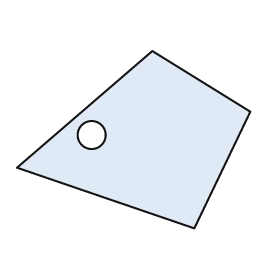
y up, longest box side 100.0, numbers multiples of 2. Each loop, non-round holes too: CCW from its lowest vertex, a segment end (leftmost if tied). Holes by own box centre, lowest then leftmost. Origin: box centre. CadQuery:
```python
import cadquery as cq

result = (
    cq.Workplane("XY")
    .moveTo(26.0, -38.0)
    .lineTo(50.0, 12.0)
    .lineTo(8.0, 38.0)
    .lineTo(-50.0, -12.0)
    .close()
    .moveTo(-18.0, 2.0)
    .circle(6.0)
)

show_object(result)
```